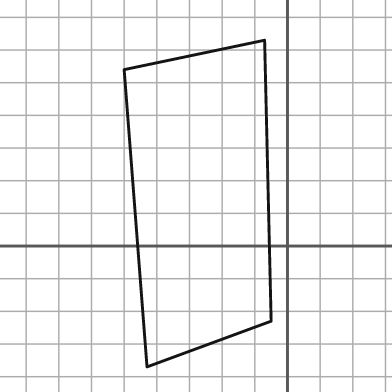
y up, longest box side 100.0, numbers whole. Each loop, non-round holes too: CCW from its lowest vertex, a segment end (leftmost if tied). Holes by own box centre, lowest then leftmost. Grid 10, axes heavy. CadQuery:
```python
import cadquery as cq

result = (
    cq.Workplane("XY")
    .moveTo(-43.0, -37.0)
    .lineTo(-5.0, -23.0)
    .lineTo(-7.0, 63.0)
    .lineTo(-50.0, 54.0)
    .close()
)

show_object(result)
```